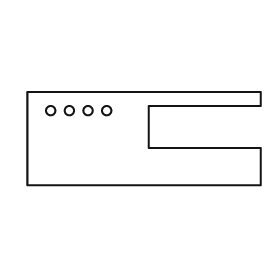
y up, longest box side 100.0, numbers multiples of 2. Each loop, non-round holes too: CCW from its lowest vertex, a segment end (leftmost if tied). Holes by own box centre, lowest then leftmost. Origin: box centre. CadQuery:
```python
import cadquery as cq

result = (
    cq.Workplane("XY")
    .moveTo(-50.0, -20.0)
    .lineTo(50.0, -20.0)
    .lineTo(50.0, -4.0)
    .lineTo(2.0, -4.0)
    .lineTo(2.0, 14.0)
    .lineTo(50.0, 14.0)
    .lineTo(50.0, 20.0)
    .lineTo(-50.0, 20.0)
    .close()
    .moveTo(-40.0, 12.0)
    .circle(2.0)
    .moveTo(-32.0, 12.0)
    .circle(2.0)
    .moveTo(-24.0, 12.0)
    .circle(2.0)
    .moveTo(-16.0, 12.0)
    .circle(2.0)
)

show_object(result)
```